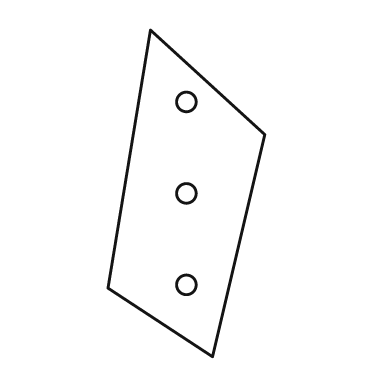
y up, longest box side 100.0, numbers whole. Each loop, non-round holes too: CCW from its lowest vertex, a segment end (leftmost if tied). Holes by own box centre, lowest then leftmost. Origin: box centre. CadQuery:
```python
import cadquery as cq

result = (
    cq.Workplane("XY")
    .moveTo(8.0, -50.0)
    .lineTo(24.0, 18.0)
    .lineTo(-11.0, 50.0)
    .lineTo(-24.0, -29.0)
    .close()
    .moveTo(0.0, -28.0)
    .circle(3.0)
    .moveTo(0.0, 0.0)
    .circle(3.0)
    .moveTo(0.0, 28.0)
    .circle(3.0)
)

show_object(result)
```